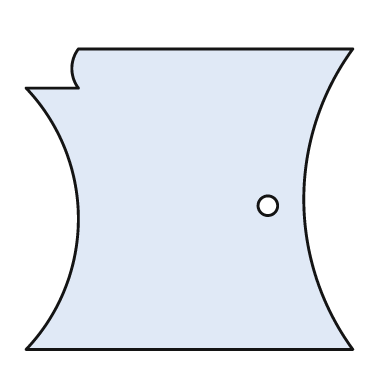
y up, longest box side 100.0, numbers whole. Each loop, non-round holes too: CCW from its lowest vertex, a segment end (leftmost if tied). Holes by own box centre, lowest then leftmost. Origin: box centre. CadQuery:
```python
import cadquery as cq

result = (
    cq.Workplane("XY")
    .moveTo(-50.0, -46.0)
    .lineTo(50.0, -46.0)
    .threePointArc((35.0, 0.0), (50.0, 46.0))
    .lineTo(-34.0, 46.0)
    .threePointArc((-36.0, 40.0), (-34.0, 34.0))
    .lineTo(-50.0, 34.0)
    .threePointArc((-34.0, -6.0), (-50.0, -46.0))
    .close()
    .moveTo(24.0, -2.0)
    .circle(3.0)
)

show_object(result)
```